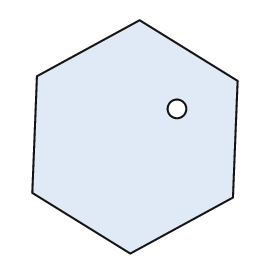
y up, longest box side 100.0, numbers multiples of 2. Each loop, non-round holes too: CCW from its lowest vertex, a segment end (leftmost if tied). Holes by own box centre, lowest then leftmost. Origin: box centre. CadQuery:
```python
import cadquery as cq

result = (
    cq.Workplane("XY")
    .moveTo(-2.0, -50.0)
    .lineTo(42.0, -26.0)
    .lineTo(44.0, 24.0)
    .lineTo(2.0, 50.0)
    .lineTo(-42.0, 26.0)
    .lineTo(-44.0, -24.0)
    .close()
    .moveTo(18.0, 12.0)
    .circle(4.0)
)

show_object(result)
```